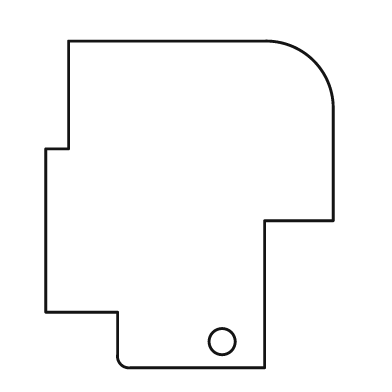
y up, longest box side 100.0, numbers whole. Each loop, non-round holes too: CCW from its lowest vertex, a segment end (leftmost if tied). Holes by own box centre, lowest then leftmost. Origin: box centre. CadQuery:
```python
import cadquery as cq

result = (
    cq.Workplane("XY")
    .moveTo(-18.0, -50.0)
    .lineTo(23.0, -50.0)
    .lineTo(23.0, -5.0)
    .lineTo(44.0, -5.0)
    .lineTo(44.0, 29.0)
    .threePointArc((38.0, 44.0), (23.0, 50.0))
    .lineTo(-37.0, 50.0)
    .lineTo(-37.0, 17.0)
    .lineTo(-44.0, 17.0)
    .lineTo(-44.0, -33.0)
    .lineTo(-22.0, -33.0)
    .lineTo(-22.0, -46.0)
    .threePointArc((-21.0, -49.0), (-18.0, -50.0))
    .close()
    .moveTo(10.0, -42.0)
    .circle(4.0)
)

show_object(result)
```